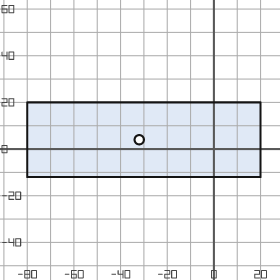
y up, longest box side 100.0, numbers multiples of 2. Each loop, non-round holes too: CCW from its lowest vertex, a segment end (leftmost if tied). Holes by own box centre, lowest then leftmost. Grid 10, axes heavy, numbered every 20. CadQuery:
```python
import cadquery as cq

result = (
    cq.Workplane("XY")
    .moveTo(-80.0, -12.0)
    .lineTo(20.0, -12.0)
    .lineTo(20.0, 20.0)
    .lineTo(-80.0, 20.0)
    .close()
    .moveTo(-32.0, 4.0)
    .circle(2.0)
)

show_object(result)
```